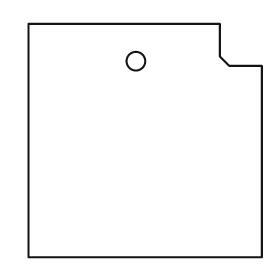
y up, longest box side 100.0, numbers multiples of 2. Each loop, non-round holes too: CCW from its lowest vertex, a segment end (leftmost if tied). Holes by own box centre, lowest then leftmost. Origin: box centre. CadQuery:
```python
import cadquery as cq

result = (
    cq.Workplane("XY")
    .moveTo(-50.0, -50.0)
    .lineTo(50.0, -50.0)
    .lineTo(50.0, 32.0)
    .lineTo(36.0, 32.0)
    .lineTo(32.0, 36.0)
    .lineTo(32.0, 50.0)
    .lineTo(-50.0, 50.0)
    .close()
    .moveTo(-4.0, 34.0)
    .circle(4.0)
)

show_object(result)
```